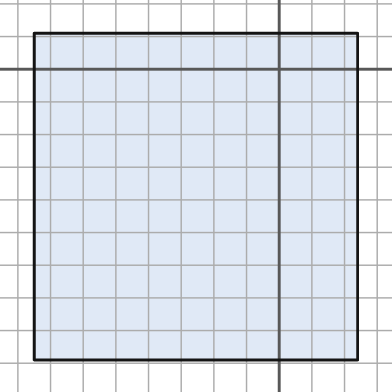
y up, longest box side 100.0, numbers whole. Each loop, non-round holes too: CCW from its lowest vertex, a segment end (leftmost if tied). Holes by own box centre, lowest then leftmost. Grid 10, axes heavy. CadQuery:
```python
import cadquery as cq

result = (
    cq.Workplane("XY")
    .moveTo(-75.0, -89.0)
    .lineTo(24.0, -89.0)
    .lineTo(24.0, 11.0)
    .lineTo(-75.0, 11.0)
    .close()
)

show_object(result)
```